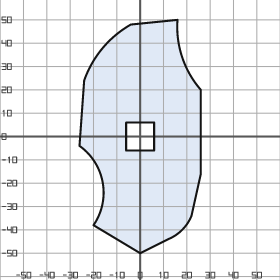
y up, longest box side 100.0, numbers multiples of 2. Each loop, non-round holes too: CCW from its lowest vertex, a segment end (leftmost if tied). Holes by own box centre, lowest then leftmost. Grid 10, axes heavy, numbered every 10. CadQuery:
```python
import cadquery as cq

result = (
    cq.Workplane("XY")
    .moveTo(0.0, -50.0)
    .lineTo(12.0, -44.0)
    .threePointArc((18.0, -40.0), (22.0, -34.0))
    .lineTo(26.0, -16.0)
    .lineTo(26.0, 20.0)
    .threePointArc((18.0, 34.0), (16.0, 50.0))
    .lineTo(-4.0, 48.0)
    .threePointArc((-16.0, 38.0), (-24.0, 24.0))
    .lineTo(-26.0, -4.0)
    .threePointArc((-16.0, -20.0), (-20.0, -38.0))
    .close()
    .moveTo(-6.0, -6.0)
    .lineTo(6.0, -6.0)
    .lineTo(6.0, 6.0)
    .lineTo(-6.0, 6.0)
    .close()
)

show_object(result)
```